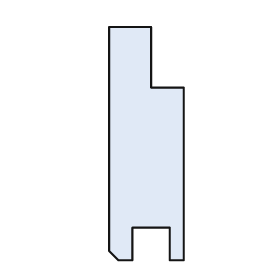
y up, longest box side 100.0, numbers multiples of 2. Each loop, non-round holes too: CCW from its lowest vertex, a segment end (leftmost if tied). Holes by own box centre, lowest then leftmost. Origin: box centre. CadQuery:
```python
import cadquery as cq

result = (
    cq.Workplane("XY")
    .moveTo(-12.0, -50.0)
    .lineTo(-6.0, -50.0)
    .lineTo(-6.0, -36.0)
    .lineTo(10.0, -36.0)
    .lineTo(10.0, -50.0)
    .lineTo(16.0, -50.0)
    .lineTo(16.0, 24.0)
    .lineTo(2.0, 24.0)
    .lineTo(2.0, 50.0)
    .lineTo(-16.0, 50.0)
    .lineTo(-16.0, -46.0)
    .close()
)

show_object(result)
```